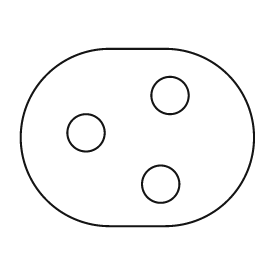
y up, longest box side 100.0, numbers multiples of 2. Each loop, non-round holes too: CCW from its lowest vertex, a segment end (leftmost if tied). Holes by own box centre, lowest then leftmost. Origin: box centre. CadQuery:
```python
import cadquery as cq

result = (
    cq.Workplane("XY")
    .moveTo(-12.0, -38.0)
    .lineTo(12.0, -38.0)
    .threePointArc((50.0, 0.0), (12.0, 38.0))
    .lineTo(-12.0, 38.0)
    .threePointArc((-50.0, 0.0), (-12.0, -38.0))
    .close()
    .moveTo(10.0, -20.0)
    .circle(8.0)
    .moveTo(-22.0, 2.0)
    .circle(8.0)
    .moveTo(14.0, 18.0)
    .circle(8.0)
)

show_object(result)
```